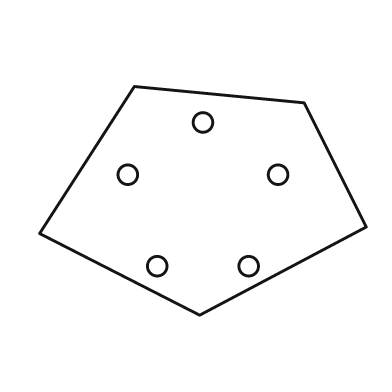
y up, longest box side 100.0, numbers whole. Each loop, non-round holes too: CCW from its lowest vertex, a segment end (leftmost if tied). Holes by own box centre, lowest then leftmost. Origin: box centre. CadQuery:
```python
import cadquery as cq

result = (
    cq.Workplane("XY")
    .moveTo(-1.0, -35.0)
    .lineTo(50.0, -8.0)
    .lineTo(31.0, 30.0)
    .lineTo(-21.0, 35.0)
    .lineTo(-50.0, -10.0)
    .close()
    .moveTo(-14.0, -20.0)
    .circle(3.0)
    .moveTo(14.0, -20.0)
    .circle(3.0)
    .moveTo(-23.0, 8.0)
    .circle(3.0)
    .moveTo(23.0, 8.0)
    .circle(3.0)
    .moveTo(0.0, 24.0)
    .circle(3.0)
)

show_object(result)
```